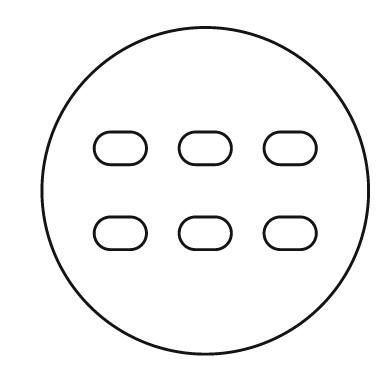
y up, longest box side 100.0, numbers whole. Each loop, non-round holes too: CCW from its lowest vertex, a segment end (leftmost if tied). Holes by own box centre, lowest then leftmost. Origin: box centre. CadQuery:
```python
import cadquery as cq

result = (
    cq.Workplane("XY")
    .moveTo(0.0, 0.0)
    .circle(50.0)
    .moveTo(-29.0, -18.0)
    .lineTo(-23.0, -18.0)
    .threePointArc((-18.0, -13.0), (-23.0, -8.0))
    .lineTo(-29.0, -8.0)
    .threePointArc((-34.0, -13.0), (-29.0, -18.0))
    .close()
    .moveTo(-3.0, -18.0)
    .lineTo(3.0, -18.0)
    .threePointArc((8.0, -13.0), (3.0, -8.0))
    .lineTo(-3.0, -8.0)
    .threePointArc((-8.0, -13.0), (-3.0, -18.0))
    .close()
    .moveTo(23.0, -18.0)
    .lineTo(29.0, -18.0)
    .threePointArc((34.0, -13.0), (29.0, -8.0))
    .lineTo(23.0, -8.0)
    .threePointArc((18.0, -13.0), (23.0, -18.0))
    .close()
    .moveTo(-29.0, 8.0)
    .lineTo(-23.0, 8.0)
    .threePointArc((-18.0, 13.0), (-23.0, 18.0))
    .lineTo(-29.0, 18.0)
    .threePointArc((-34.0, 13.0), (-29.0, 8.0))
    .close()
    .moveTo(-3.0, 8.0)
    .lineTo(3.0, 8.0)
    .threePointArc((8.0, 13.0), (3.0, 18.0))
    .lineTo(-3.0, 18.0)
    .threePointArc((-8.0, 13.0), (-3.0, 8.0))
    .close()
    .moveTo(23.0, 8.0)
    .lineTo(29.0, 8.0)
    .threePointArc((34.0, 13.0), (29.0, 18.0))
    .lineTo(23.0, 18.0)
    .threePointArc((18.0, 13.0), (23.0, 8.0))
    .close()
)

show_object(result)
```